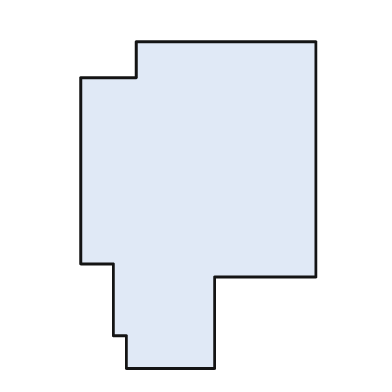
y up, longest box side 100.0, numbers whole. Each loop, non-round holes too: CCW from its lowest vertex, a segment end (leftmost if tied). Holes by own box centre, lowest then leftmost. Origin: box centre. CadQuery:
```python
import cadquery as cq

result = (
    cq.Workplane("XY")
    .moveTo(-22.0, -50.0)
    .lineTo(5.0, -50.0)
    .lineTo(5.0, -22.0)
    .lineTo(36.0, -22.0)
    .lineTo(36.0, 50.0)
    .lineTo(-19.0, 50.0)
    .lineTo(-19.0, 39.0)
    .lineTo(-36.0, 39.0)
    .lineTo(-36.0, -18.0)
    .lineTo(-26.0, -18.0)
    .lineTo(-26.0, -40.0)
    .lineTo(-22.0, -40.0)
    .close()
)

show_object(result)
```